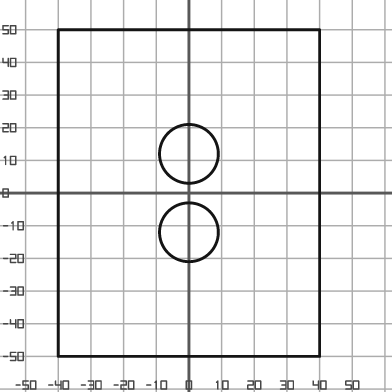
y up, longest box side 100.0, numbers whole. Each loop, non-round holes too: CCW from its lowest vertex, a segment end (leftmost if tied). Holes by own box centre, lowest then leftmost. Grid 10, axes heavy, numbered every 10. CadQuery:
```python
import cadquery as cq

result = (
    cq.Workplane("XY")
    .moveTo(-40.0, -50.0)
    .lineTo(40.0, -50.0)
    .lineTo(40.0, 50.0)
    .lineTo(-40.0, 50.0)
    .close()
    .moveTo(0.0, -12.0)
    .circle(9.0)
    .moveTo(0.0, 12.0)
    .circle(9.0)
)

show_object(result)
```